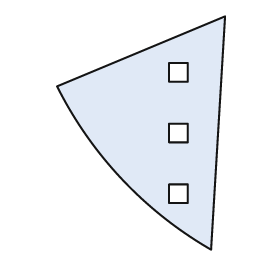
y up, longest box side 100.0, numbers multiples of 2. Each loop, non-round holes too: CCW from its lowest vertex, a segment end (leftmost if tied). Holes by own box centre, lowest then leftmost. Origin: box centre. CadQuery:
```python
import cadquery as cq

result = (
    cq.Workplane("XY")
    .moveTo(30.0, -50.0)
    .lineTo(36.0, 50.0)
    .lineTo(-36.0, 20.0)
    .threePointArc((-8.0, -20.0), (30.0, -50.0))
    .close()
    .moveTo(12.0, -30.0)
    .lineTo(20.0, -30.0)
    .lineTo(20.0, -22.0)
    .lineTo(12.0, -22.0)
    .close()
    .moveTo(12.0, -4.0)
    .lineTo(20.0, -4.0)
    .lineTo(20.0, 4.0)
    .lineTo(12.0, 4.0)
    .close()
    .moveTo(12.0, 22.0)
    .lineTo(20.0, 22.0)
    .lineTo(20.0, 30.0)
    .lineTo(12.0, 30.0)
    .close()
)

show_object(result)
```